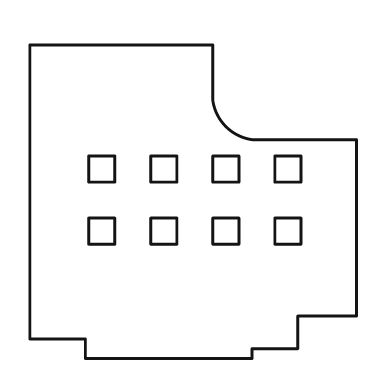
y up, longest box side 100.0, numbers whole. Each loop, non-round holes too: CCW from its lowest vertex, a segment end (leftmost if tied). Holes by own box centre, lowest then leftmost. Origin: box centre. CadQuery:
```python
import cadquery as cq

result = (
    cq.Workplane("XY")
    .moveTo(-33.0, -48.0)
    .lineTo(18.0, -48.0)
    .lineTo(18.0, -45.0)
    .lineTo(32.0, -45.0)
    .lineTo(32.0, -35.0)
    .lineTo(50.0, -35.0)
    .lineTo(50.0, 19.0)
    .lineTo(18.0, 19.0)
    .threePointArc((10.0, 23.0), (6.0, 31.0))
    .lineTo(6.0, 48.0)
    .lineTo(-50.0, 48.0)
    .lineTo(-50.0, -42.0)
    .lineTo(-33.0, -42.0)
    .close()
    .moveTo(-32.0, -13.0)
    .lineTo(-24.0, -13.0)
    .lineTo(-24.0, -5.0)
    .lineTo(-32.0, -5.0)
    .close()
    .moveTo(-13.0, -13.0)
    .lineTo(-5.0, -13.0)
    .lineTo(-5.0, -5.0)
    .lineTo(-13.0, -5.0)
    .close()
    .moveTo(6.0, -13.0)
    .lineTo(14.0, -13.0)
    .lineTo(14.0, -5.0)
    .lineTo(6.0, -5.0)
    .close()
    .moveTo(25.0, -13.0)
    .lineTo(33.0, -13.0)
    .lineTo(33.0, -5.0)
    .lineTo(25.0, -5.0)
    .close()
    .moveTo(-32.0, 6.0)
    .lineTo(-24.0, 6.0)
    .lineTo(-24.0, 14.0)
    .lineTo(-32.0, 14.0)
    .close()
    .moveTo(-13.0, 6.0)
    .lineTo(-5.0, 6.0)
    .lineTo(-5.0, 14.0)
    .lineTo(-13.0, 14.0)
    .close()
    .moveTo(6.0, 6.0)
    .lineTo(14.0, 6.0)
    .lineTo(14.0, 14.0)
    .lineTo(6.0, 14.0)
    .close()
    .moveTo(25.0, 6.0)
    .lineTo(33.0, 6.0)
    .lineTo(33.0, 14.0)
    .lineTo(25.0, 14.0)
    .close()
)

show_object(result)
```